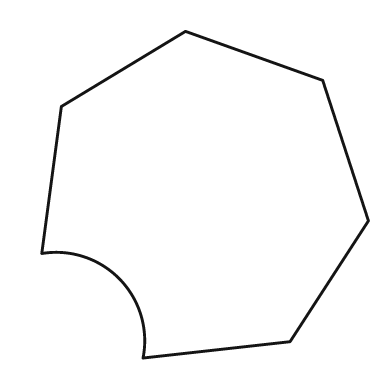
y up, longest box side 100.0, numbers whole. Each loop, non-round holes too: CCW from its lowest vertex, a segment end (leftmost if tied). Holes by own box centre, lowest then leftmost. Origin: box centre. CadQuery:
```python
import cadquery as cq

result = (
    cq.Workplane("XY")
    .moveTo(-19.0, -50.0)
    .lineTo(26.0, -45.0)
    .lineTo(50.0, -8.0)
    .lineTo(36.0, 35.0)
    .lineTo(-6.0, 50.0)
    .lineTo(-44.0, 27.0)
    .lineTo(-50.0, -18.0)
    .threePointArc((-26.0, -26.0), (-19.0, -50.0))
    .close()
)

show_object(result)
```